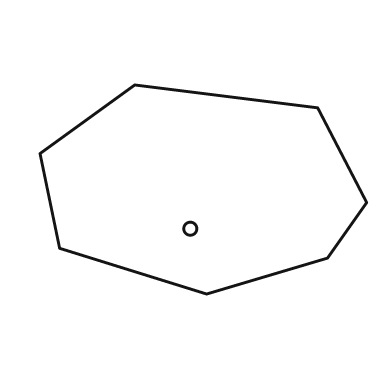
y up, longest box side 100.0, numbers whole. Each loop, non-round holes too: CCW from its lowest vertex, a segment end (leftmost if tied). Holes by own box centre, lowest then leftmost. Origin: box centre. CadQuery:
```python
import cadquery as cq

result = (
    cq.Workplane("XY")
    .moveTo(1.0, -32.0)
    .lineTo(38.0, -21.0)
    .lineTo(50.0, -4.0)
    .lineTo(35.0, 25.0)
    .lineTo(-21.0, 32.0)
    .lineTo(-50.0, 11.0)
    .lineTo(-44.0, -18.0)
    .close()
    .moveTo(-4.0, -12.0)
    .circle(2.0)
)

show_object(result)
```